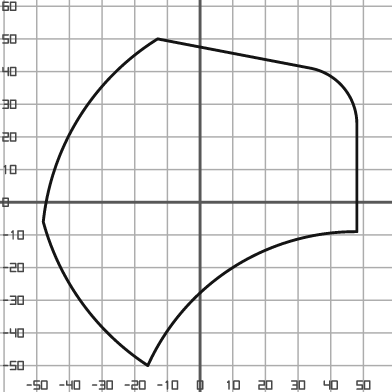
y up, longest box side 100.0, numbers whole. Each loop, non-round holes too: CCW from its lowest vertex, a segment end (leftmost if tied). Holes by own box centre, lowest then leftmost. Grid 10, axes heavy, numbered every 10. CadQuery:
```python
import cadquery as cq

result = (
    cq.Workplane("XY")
    .moveTo(-16.0, -50.0)
    .threePointArc((10.0, -20.0), (48.0, -9.0))
    .lineTo(48.0, 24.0)
    .threePointArc((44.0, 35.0), (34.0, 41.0))
    .lineTo(-13.0, 50.0)
    .threePointArc((-37.0, 26.0), (-48.0, -6.0))
    .threePointArc((-36.0, -31.0), (-16.0, -50.0))
    .close()
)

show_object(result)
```